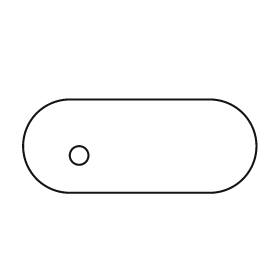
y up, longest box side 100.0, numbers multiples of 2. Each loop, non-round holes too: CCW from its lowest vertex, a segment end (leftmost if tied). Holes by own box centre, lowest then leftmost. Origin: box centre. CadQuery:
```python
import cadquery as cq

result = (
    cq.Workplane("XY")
    .moveTo(-30.0, -20.0)
    .lineTo(30.0, -20.0)
    .threePointArc((50.0, 0.0), (30.0, 20.0))
    .lineTo(-30.0, 20.0)
    .threePointArc((-50.0, 0.0), (-30.0, -20.0))
    .close()
    .moveTo(-26.0, -4.0)
    .circle(4.0)
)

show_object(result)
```